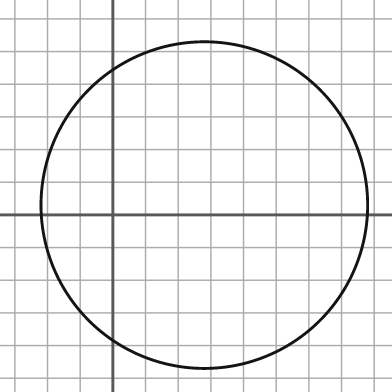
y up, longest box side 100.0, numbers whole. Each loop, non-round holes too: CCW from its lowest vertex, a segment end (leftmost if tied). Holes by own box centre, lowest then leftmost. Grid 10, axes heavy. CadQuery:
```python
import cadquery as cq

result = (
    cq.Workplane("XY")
    .moveTo(28.0, 3.0)
    .circle(50.0)
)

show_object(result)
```